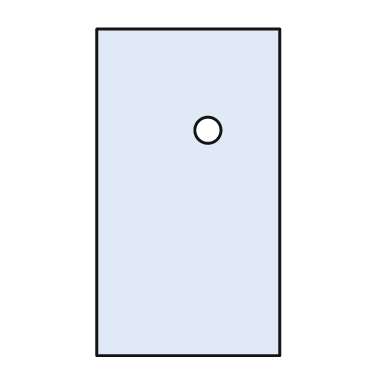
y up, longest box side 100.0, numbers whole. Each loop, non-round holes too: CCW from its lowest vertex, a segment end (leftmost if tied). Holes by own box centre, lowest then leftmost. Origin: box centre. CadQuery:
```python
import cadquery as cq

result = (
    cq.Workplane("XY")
    .moveTo(-28.0, -50.0)
    .lineTo(28.0, -50.0)
    .lineTo(28.0, 50.0)
    .lineTo(-28.0, 50.0)
    .close()
    .moveTo(6.0, 19.0)
    .circle(4.0)
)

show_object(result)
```